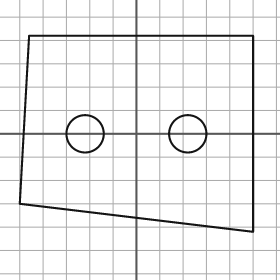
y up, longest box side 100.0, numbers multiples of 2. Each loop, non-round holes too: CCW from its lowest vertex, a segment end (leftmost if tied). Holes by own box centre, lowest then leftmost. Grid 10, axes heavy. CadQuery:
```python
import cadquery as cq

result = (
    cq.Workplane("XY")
    .moveTo(50.0, -42.0)
    .lineTo(50.0, 42.0)
    .lineTo(-46.0, 42.0)
    .lineTo(-50.0, -30.0)
    .close()
    .moveTo(-22.0, 0.0)
    .circle(8.0)
    .moveTo(22.0, 0.0)
    .circle(8.0)
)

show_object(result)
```